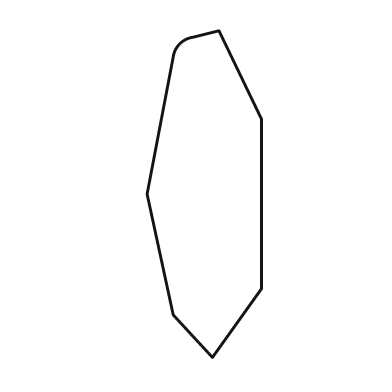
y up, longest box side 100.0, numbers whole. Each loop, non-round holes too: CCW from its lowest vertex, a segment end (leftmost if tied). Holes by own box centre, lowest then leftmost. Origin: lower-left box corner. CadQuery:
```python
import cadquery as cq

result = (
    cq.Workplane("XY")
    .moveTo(20.0, 0.0)
    .lineTo(35.0, 21.0)
    .lineTo(35.0, 73.0)
    .lineTo(22.0, 100.0)
    .lineTo(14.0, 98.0)
    .threePointArc((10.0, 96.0), (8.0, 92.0))
    .lineTo(0.0, 50.0)
    .lineTo(8.0, 13.0)
    .close()
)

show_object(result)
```